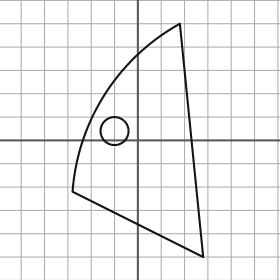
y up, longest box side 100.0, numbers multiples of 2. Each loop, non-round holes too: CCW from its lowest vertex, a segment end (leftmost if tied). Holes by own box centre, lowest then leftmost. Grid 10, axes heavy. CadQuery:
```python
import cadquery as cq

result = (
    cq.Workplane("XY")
    .moveTo(28.0, -50.0)
    .lineTo(18.0, 50.0)
    .threePointArc((-14.0, 20.0), (-28.0, -22.0))
    .close()
    .moveTo(-10.0, 4.0)
    .circle(6.0)
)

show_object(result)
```